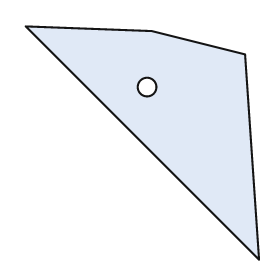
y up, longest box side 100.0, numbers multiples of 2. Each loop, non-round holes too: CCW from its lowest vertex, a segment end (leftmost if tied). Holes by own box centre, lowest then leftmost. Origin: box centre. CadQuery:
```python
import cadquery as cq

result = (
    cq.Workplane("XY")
    .moveTo(50.0, -50.0)
    .lineTo(44.0, 38.0)
    .lineTo(4.0, 48.0)
    .lineTo(-50.0, 50.0)
    .close()
    .moveTo(2.0, 24.0)
    .circle(4.0)
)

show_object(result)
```